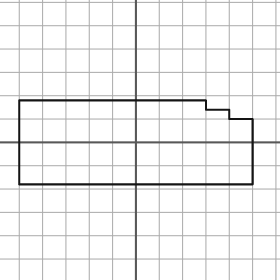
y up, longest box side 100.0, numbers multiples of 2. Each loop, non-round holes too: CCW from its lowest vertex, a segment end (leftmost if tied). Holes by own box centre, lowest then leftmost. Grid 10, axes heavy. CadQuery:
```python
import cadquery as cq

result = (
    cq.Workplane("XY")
    .moveTo(-50.0, -18.0)
    .lineTo(50.0, -18.0)
    .lineTo(50.0, 10.0)
    .lineTo(40.0, 10.0)
    .lineTo(40.0, 14.0)
    .lineTo(30.0, 14.0)
    .lineTo(30.0, 18.0)
    .lineTo(-50.0, 18.0)
    .close()
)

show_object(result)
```